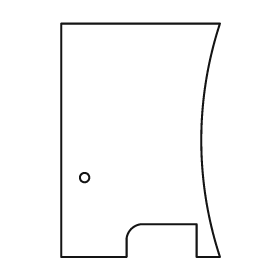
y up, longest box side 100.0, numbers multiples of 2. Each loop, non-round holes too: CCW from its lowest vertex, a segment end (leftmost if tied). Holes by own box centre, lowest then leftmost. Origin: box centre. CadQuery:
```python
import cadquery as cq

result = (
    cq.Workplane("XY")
    .moveTo(-34.0, -50.0)
    .lineTo(-6.0, -50.0)
    .lineTo(-6.0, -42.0)
    .threePointArc((-4.0, -38.0), (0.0, -36.0))
    .lineTo(24.0, -36.0)
    .lineTo(24.0, -50.0)
    .lineTo(34.0, -50.0)
    .threePointArc((26.0, 0.0), (34.0, 50.0))
    .lineTo(-34.0, 50.0)
    .close()
    .moveTo(-24.0, -16.0)
    .circle(2.0)
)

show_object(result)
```